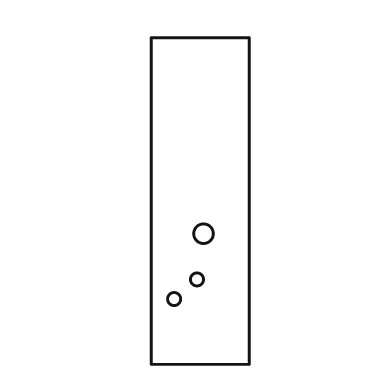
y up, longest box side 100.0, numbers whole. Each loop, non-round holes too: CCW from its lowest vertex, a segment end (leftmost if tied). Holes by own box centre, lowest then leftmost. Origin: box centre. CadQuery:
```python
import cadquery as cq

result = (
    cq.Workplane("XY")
    .moveTo(-15.0, -50.0)
    .lineTo(15.0, -50.0)
    .lineTo(15.0, 50.0)
    .lineTo(-15.0, 50.0)
    .close()
    .moveTo(-8.0, -30.0)
    .circle(2.0)
    .moveTo(-1.0, -24.0)
    .circle(2.0)
    .moveTo(1.0, -10.0)
    .circle(3.0)
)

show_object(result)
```